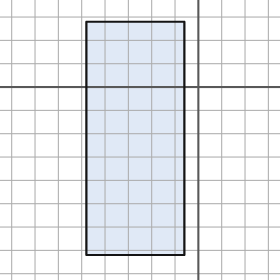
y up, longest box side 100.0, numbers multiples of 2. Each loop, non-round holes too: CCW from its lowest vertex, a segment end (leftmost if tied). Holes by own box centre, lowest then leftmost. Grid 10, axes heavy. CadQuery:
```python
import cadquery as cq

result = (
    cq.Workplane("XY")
    .moveTo(-48.0, -72.0)
    .lineTo(-6.0, -72.0)
    .lineTo(-6.0, 28.0)
    .lineTo(-48.0, 28.0)
    .close()
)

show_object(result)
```